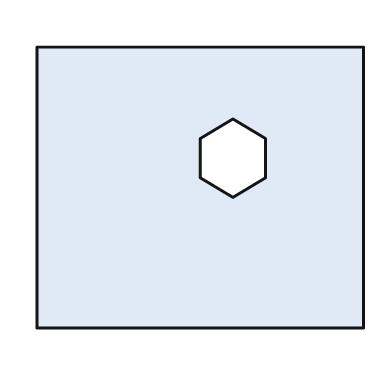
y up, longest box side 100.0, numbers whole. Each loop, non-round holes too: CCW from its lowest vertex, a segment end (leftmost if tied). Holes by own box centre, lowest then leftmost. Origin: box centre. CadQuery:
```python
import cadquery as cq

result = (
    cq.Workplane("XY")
    .moveTo(-50.0, -43.0)
    .lineTo(50.0, -43.0)
    .lineTo(50.0, 43.0)
    .lineTo(-50.0, 43.0)
    .close()
    .moveTo(10.0, -3.0)
    .lineTo(20.0, 3.0)
    .lineTo(20.0, 15.0)
    .lineTo(10.0, 21.0)
    .lineTo(0.0, 15.0)
    .lineTo(0.0, 3.0)
    .close()
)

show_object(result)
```